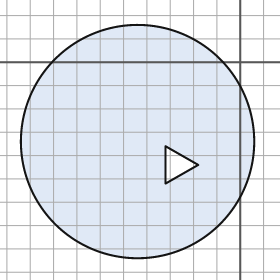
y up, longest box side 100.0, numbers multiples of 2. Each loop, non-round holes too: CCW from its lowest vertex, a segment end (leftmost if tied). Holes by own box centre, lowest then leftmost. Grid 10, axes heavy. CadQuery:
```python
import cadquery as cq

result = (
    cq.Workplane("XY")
    .moveTo(-44.0, -34.0)
    .circle(50.0)
    .moveTo(-32.0, -52.0)
    .lineTo(-18.0, -44.0)
    .lineTo(-32.0, -36.0)
    .close()
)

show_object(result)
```